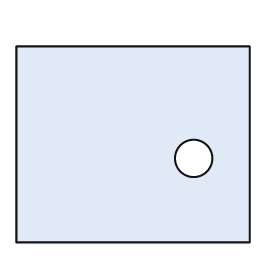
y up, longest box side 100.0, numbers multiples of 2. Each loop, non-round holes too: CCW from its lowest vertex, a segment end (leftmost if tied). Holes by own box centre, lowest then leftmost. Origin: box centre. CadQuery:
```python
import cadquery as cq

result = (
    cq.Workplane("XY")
    .moveTo(-50.0, -42.0)
    .lineTo(50.0, -42.0)
    .lineTo(50.0, 42.0)
    .lineTo(-50.0, 42.0)
    .close()
    .moveTo(26.0, -6.0)
    .circle(8.0)
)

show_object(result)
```